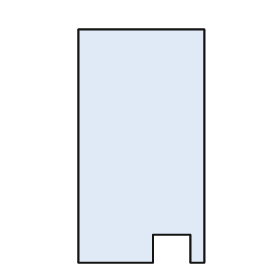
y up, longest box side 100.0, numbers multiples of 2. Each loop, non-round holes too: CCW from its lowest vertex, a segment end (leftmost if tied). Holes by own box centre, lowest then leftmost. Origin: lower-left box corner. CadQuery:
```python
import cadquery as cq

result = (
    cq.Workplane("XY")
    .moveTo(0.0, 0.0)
    .lineTo(32.0, 0.0)
    .lineTo(32.0, 12.0)
    .lineTo(48.0, 12.0)
    .lineTo(48.0, 0.0)
    .lineTo(54.0, 0.0)
    .lineTo(54.0, 100.0)
    .lineTo(0.0, 100.0)
    .close()
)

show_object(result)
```